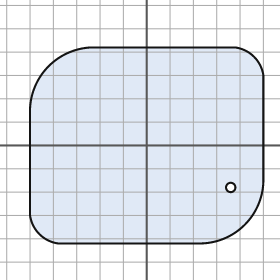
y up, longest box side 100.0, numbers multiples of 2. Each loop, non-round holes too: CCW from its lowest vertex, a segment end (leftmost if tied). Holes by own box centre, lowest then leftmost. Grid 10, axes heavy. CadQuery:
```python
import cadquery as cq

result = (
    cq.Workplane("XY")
    .moveTo(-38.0, -42.0)
    .lineTo(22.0, -42.0)
    .threePointArc((42.0, -34.0), (50.0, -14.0))
    .lineTo(50.0, 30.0)
    .threePointArc((46.0, 38.0), (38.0, 42.0))
    .lineTo(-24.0, 42.0)
    .threePointArc((-42.0, 34.0), (-50.0, 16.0))
    .lineTo(-50.0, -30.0)
    .threePointArc((-46.0, -38.0), (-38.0, -42.0))
    .close()
    .moveTo(36.0, -18.0)
    .circle(2.0)
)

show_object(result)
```